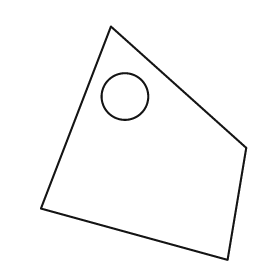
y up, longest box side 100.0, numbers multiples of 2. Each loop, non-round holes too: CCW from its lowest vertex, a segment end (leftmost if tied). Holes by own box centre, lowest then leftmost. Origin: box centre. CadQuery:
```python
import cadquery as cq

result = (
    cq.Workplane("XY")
    .moveTo(36.0, -50.0)
    .lineTo(44.0, -2.0)
    .lineTo(-14.0, 50.0)
    .lineTo(-44.0, -28.0)
    .close()
    .moveTo(-8.0, 20.0)
    .circle(10.0)
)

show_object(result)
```